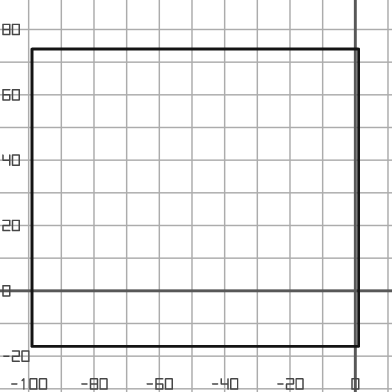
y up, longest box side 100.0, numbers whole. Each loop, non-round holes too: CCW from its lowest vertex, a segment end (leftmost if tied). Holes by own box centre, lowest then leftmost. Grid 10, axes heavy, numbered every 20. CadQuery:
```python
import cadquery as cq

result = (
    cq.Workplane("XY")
    .moveTo(-99.0, -17.0)
    .lineTo(1.0, -17.0)
    .lineTo(1.0, 74.0)
    .lineTo(-99.0, 74.0)
    .close()
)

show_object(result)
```